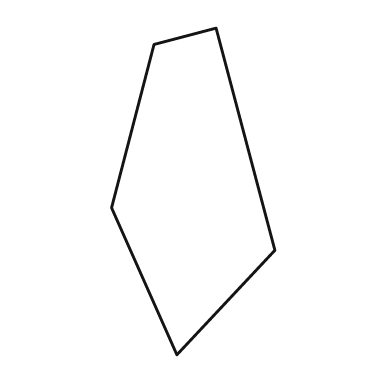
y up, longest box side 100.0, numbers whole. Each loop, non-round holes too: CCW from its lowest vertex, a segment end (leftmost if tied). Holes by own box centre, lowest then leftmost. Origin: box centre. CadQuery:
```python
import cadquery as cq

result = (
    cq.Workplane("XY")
    .moveTo(-5.0, -50.0)
    .lineTo(25.0, -18.0)
    .lineTo(7.0, 50.0)
    .lineTo(-12.0, 45.0)
    .lineTo(-25.0, -5.0)
    .close()
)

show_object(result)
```